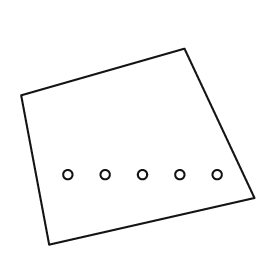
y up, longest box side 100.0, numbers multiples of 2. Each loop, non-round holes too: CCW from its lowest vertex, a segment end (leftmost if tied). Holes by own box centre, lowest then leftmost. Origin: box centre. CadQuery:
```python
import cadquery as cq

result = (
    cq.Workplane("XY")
    .moveTo(-38.0, -42.0)
    .lineTo(50.0, -22.0)
    .lineTo(20.0, 42.0)
    .lineTo(-50.0, 22.0)
    .close()
    .moveTo(-30.0, -12.0)
    .circle(2.0)
    .moveTo(-14.0, -12.0)
    .circle(2.0)
    .moveTo(2.0, -12.0)
    .circle(2.0)
    .moveTo(18.0, -12.0)
    .circle(2.0)
    .moveTo(34.0, -12.0)
    .circle(2.0)
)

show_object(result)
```